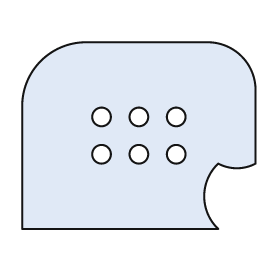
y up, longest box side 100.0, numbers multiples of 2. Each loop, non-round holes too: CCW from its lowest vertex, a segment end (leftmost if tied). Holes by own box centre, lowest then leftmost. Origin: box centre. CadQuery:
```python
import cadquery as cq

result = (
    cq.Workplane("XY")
    .moveTo(-50.0, -40.0)
    .lineTo(34.0, -40.0)
    .threePointArc((28.0, -26.0), (34.0, -12.0))
    .threePointArc((42.0, -14.0), (50.0, -12.0))
    .lineTo(50.0, 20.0)
    .threePointArc((44.0, 34.0), (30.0, 40.0))
    .lineTo(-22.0, 40.0)
    .threePointArc((-42.0, 32.0), (-50.0, 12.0))
    .close()
    .moveTo(-16.0, -8.0)
    .circle(4.0)
    .moveTo(0.0, -8.0)
    .circle(4.0)
    .moveTo(16.0, -8.0)
    .circle(4.0)
    .moveTo(-16.0, 8.0)
    .circle(4.0)
    .moveTo(0.0, 8.0)
    .circle(4.0)
    .moveTo(16.0, 8.0)
    .circle(4.0)
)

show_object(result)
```